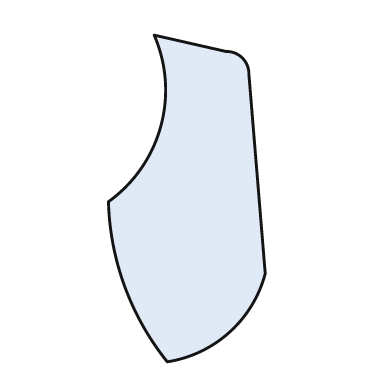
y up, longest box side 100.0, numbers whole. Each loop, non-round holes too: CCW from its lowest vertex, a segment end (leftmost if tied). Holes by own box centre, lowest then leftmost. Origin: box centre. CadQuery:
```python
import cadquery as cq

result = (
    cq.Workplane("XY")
    .moveTo(-6.0, -50.0)
    .threePointArc((13.0, -41.0), (24.0, -23.0))
    .lineTo(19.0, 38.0)
    .threePointArc((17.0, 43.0), (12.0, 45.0))
    .lineTo(-10.0, 50.0)
    .threePointArc((-8.0, 22.0), (-24.0, -1.0))
    .threePointArc((-19.0, -27.0), (-6.0, -50.0))
    .close()
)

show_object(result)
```